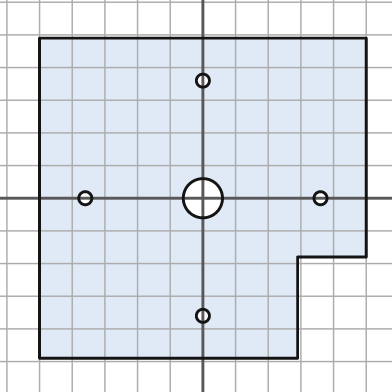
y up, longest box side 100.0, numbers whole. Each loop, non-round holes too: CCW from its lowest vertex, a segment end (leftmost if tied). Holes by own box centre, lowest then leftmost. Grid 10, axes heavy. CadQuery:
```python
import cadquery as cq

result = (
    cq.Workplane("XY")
    .moveTo(-50.0, -49.0)
    .lineTo(29.0, -49.0)
    .lineTo(29.0, -18.0)
    .lineTo(50.0, -18.0)
    .lineTo(50.0, 49.0)
    .lineTo(-50.0, 49.0)
    .close()
    .moveTo(0.0, -36.0)
    .circle(2.0)
    .moveTo(-36.0, 0.0)
    .circle(2.0)
    .moveTo(0.0, 0.0)
    .circle(6.0)
    .moveTo(36.0, 0.0)
    .circle(2.0)
    .moveTo(0.0, 36.0)
    .circle(2.0)
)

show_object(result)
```